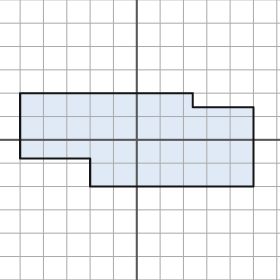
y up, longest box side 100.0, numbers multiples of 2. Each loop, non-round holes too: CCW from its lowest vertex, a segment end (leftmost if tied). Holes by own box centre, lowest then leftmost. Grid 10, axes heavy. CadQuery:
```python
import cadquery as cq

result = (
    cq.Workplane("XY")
    .moveTo(-20.0, -20.0)
    .lineTo(50.0, -20.0)
    .lineTo(50.0, 14.0)
    .lineTo(24.0, 14.0)
    .lineTo(24.0, 20.0)
    .lineTo(-50.0, 20.0)
    .lineTo(-50.0, -8.0)
    .lineTo(-20.0, -8.0)
    .close()
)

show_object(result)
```